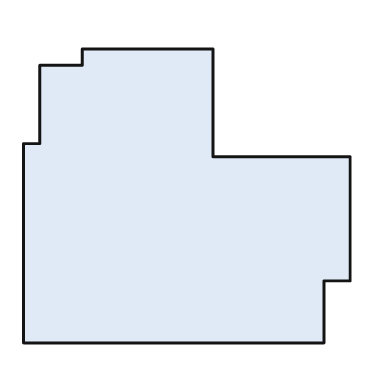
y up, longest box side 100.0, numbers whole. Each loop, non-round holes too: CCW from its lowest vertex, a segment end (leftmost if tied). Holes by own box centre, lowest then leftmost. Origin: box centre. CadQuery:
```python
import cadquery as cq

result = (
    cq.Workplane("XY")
    .moveTo(-50.0, -45.0)
    .lineTo(42.0, -45.0)
    .lineTo(42.0, -26.0)
    .lineTo(50.0, -26.0)
    .lineTo(50.0, 12.0)
    .lineTo(8.0, 12.0)
    .lineTo(8.0, 45.0)
    .lineTo(-32.0, 45.0)
    .lineTo(-32.0, 40.0)
    .lineTo(-45.0, 40.0)
    .lineTo(-45.0, 16.0)
    .lineTo(-50.0, 16.0)
    .close()
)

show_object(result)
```